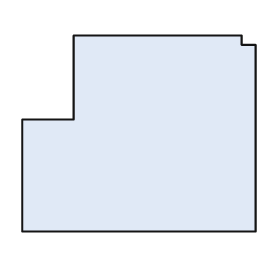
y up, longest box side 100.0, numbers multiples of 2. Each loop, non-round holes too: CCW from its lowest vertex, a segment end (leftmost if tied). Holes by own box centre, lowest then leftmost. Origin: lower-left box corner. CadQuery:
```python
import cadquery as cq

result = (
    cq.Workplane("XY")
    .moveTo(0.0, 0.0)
    .lineTo(100.0, 0.0)
    .lineTo(100.0, 80.0)
    .lineTo(94.0, 80.0)
    .lineTo(94.0, 84.0)
    .lineTo(22.0, 84.0)
    .lineTo(22.0, 48.0)
    .lineTo(0.0, 48.0)
    .close()
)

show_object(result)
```